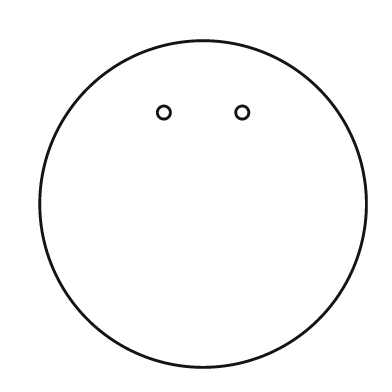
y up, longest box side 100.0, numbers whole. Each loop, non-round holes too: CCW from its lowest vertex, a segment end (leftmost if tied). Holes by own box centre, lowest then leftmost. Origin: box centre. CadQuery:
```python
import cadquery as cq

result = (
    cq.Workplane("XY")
    .moveTo(0.0, 0.0)
    .circle(50.0)
    .moveTo(-12.0, 28.0)
    .circle(2.0)
    .moveTo(12.0, 28.0)
    .circle(2.0)
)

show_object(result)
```